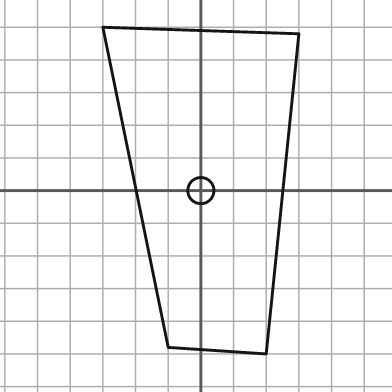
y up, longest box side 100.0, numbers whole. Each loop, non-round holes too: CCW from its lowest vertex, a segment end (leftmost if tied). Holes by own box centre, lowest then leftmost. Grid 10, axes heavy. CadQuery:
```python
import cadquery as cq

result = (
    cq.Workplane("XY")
    .moveTo(20.0, -50.0)
    .lineTo(30.0, 48.0)
    .lineTo(-30.0, 50.0)
    .lineTo(-10.0, -48.0)
    .close()
    .moveTo(0.0, 0.0)
    .circle(4.0)
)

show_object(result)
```